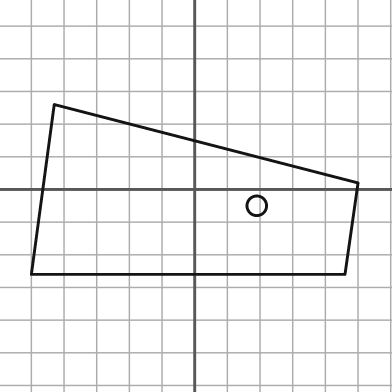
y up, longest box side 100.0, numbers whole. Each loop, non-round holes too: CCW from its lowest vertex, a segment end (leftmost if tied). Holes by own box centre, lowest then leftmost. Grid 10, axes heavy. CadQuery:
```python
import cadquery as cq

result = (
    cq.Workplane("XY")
    .moveTo(-50.0, -26.0)
    .lineTo(46.0, -26.0)
    .lineTo(50.0, 2.0)
    .lineTo(-43.0, 26.0)
    .close()
    .moveTo(19.0, -5.0)
    .circle(3.0)
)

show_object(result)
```